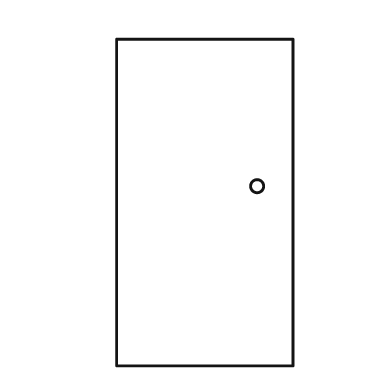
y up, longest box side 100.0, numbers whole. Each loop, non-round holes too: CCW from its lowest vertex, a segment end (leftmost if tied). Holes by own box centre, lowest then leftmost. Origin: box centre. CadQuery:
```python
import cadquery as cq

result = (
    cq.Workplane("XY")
    .moveTo(-27.0, -50.0)
    .lineTo(27.0, -50.0)
    .lineTo(27.0, 50.0)
    .lineTo(-27.0, 50.0)
    .close()
    .moveTo(16.0, 5.0)
    .circle(2.0)
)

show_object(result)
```